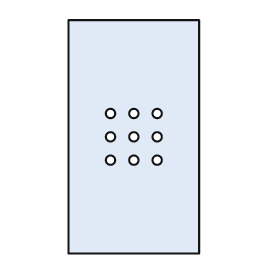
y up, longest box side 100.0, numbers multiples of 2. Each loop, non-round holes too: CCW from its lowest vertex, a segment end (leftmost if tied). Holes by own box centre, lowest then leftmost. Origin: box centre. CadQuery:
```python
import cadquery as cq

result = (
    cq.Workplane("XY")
    .moveTo(-28.0, -50.0)
    .lineTo(28.0, -50.0)
    .lineTo(28.0, 50.0)
    .lineTo(-28.0, 50.0)
    .close()
    .moveTo(-10.0, -10.0)
    .circle(2.0)
    .moveTo(0.0, -10.0)
    .circle(2.0)
    .moveTo(10.0, -10.0)
    .circle(2.0)
    .moveTo(-10.0, 0.0)
    .circle(2.0)
    .moveTo(0.0, 0.0)
    .circle(2.0)
    .moveTo(10.0, 0.0)
    .circle(2.0)
    .moveTo(-10.0, 10.0)
    .circle(2.0)
    .moveTo(0.0, 10.0)
    .circle(2.0)
    .moveTo(10.0, 10.0)
    .circle(2.0)
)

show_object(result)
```